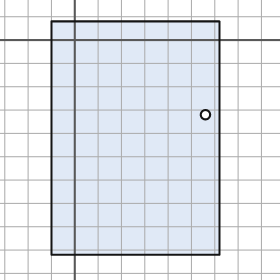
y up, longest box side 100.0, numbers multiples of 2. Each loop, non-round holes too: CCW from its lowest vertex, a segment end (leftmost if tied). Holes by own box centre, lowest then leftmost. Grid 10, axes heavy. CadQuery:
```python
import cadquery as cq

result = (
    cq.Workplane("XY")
    .moveTo(-10.0, -92.0)
    .lineTo(62.0, -92.0)
    .lineTo(62.0, 8.0)
    .lineTo(-10.0, 8.0)
    .close()
    .moveTo(56.0, -32.0)
    .circle(2.0)
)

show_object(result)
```